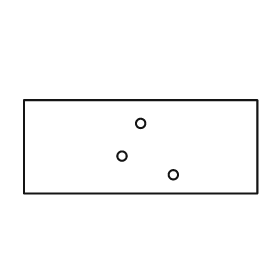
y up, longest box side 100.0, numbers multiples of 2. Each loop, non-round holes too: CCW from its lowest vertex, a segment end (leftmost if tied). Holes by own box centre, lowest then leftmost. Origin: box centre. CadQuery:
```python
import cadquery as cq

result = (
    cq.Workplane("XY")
    .moveTo(-50.0, -20.0)
    .lineTo(50.0, -20.0)
    .lineTo(50.0, 20.0)
    .lineTo(-50.0, 20.0)
    .close()
    .moveTo(14.0, -12.0)
    .circle(2.0)
    .moveTo(-8.0, -4.0)
    .circle(2.0)
    .moveTo(0.0, 10.0)
    .circle(2.0)
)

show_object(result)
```